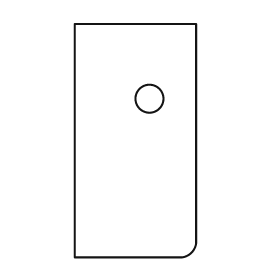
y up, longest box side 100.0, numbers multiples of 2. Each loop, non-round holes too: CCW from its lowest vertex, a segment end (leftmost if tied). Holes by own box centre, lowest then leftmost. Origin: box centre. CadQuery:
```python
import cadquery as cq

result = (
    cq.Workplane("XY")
    .moveTo(-26.0, -50.0)
    .lineTo(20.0, -50.0)
    .threePointArc((24.0, -48.0), (26.0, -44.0))
    .lineTo(26.0, 50.0)
    .lineTo(-26.0, 50.0)
    .close()
    .moveTo(6.0, 18.0)
    .circle(6.0)
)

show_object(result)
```